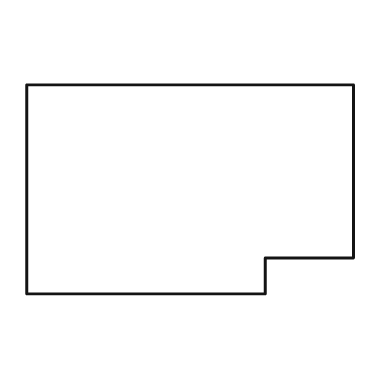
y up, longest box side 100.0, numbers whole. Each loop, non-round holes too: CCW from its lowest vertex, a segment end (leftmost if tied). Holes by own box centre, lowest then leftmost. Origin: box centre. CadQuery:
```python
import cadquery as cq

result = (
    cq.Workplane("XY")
    .moveTo(-50.0, -32.0)
    .lineTo(23.0, -32.0)
    .lineTo(23.0, -21.0)
    .lineTo(50.0, -21.0)
    .lineTo(50.0, 32.0)
    .lineTo(-50.0, 32.0)
    .close()
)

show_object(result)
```